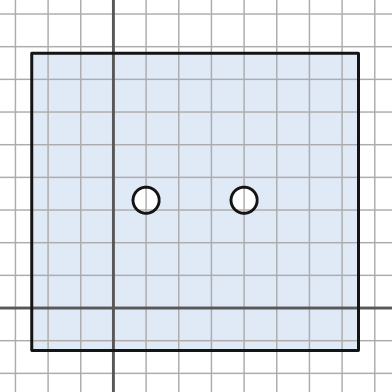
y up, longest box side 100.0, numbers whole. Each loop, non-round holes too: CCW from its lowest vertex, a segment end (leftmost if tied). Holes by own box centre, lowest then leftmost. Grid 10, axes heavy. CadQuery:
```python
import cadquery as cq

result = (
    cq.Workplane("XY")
    .moveTo(-25.0, -13.0)
    .lineTo(75.0, -13.0)
    .lineTo(75.0, 78.0)
    .lineTo(-25.0, 78.0)
    .close()
    .moveTo(10.0, 33.0)
    .circle(4.0)
    .moveTo(40.0, 33.0)
    .circle(4.0)
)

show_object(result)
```